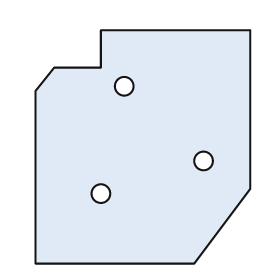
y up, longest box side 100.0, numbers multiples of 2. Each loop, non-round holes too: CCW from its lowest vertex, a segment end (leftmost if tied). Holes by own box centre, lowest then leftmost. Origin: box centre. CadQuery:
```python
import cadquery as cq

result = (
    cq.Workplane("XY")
    .moveTo(-46.0, -50.0)
    .lineTo(22.0, -50.0)
    .lineTo(46.0, -18.0)
    .lineTo(46.0, 50.0)
    .lineTo(-18.0, 50.0)
    .lineTo(-18.0, 34.0)
    .lineTo(-38.0, 34.0)
    .lineTo(-46.0, 24.0)
    .close()
    .moveTo(-18.0, -20.0)
    .circle(4.0)
    .moveTo(26.0, -6.0)
    .circle(4.0)
    .moveTo(-8.0, 26.0)
    .circle(4.0)
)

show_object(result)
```